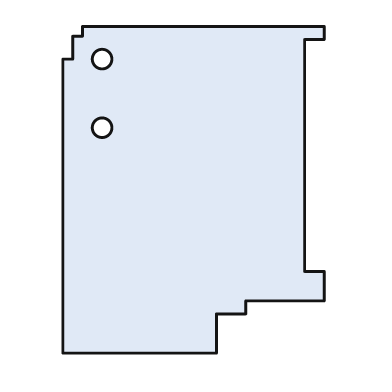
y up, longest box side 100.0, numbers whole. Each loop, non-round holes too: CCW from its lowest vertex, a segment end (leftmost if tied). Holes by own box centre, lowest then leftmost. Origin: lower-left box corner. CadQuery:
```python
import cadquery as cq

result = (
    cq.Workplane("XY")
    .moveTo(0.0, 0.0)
    .lineTo(47.0, 0.0)
    .lineTo(47.0, 12.0)
    .lineTo(56.0, 12.0)
    .lineTo(56.0, 16.0)
    .lineTo(80.0, 16.0)
    .lineTo(80.0, 25.0)
    .lineTo(74.0, 25.0)
    .lineTo(74.0, 96.0)
    .lineTo(80.0, 96.0)
    .lineTo(80.0, 100.0)
    .lineTo(6.0, 100.0)
    .lineTo(6.0, 97.0)
    .lineTo(3.0, 97.0)
    .lineTo(3.0, 90.0)
    .lineTo(0.0, 90.0)
    .close()
    .moveTo(12.0, 69.0)
    .circle(3.0)
    .moveTo(12.0, 90.0)
    .circle(3.0)
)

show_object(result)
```